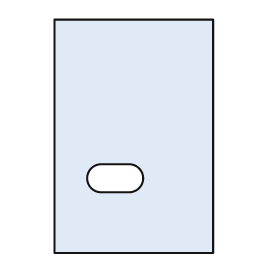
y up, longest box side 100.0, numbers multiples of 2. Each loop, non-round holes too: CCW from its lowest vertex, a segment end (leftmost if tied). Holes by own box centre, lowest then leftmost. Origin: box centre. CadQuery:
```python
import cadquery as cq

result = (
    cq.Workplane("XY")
    .moveTo(-34.0, -50.0)
    .lineTo(34.0, -50.0)
    .lineTo(34.0, 50.0)
    .lineTo(-34.0, 50.0)
    .close()
    .moveTo(-14.0, -24.0)
    .lineTo(-2.0, -24.0)
    .threePointArc((4.0, -18.0), (-2.0, -12.0))
    .lineTo(-14.0, -12.0)
    .threePointArc((-20.0, -18.0), (-14.0, -24.0))
    .close()
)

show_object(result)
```